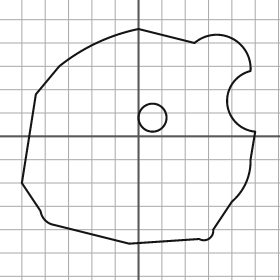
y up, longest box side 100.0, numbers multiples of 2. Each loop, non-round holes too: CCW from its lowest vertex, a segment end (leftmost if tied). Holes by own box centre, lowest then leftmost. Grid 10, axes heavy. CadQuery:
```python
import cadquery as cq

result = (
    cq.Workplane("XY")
    .moveTo(-4.0, -46.0)
    .lineTo(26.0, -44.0)
    .threePointArc((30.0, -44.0), (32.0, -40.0))
    .lineTo(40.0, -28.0)
    .threePointArc((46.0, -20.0), (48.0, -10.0))
    .lineTo(50.0, 2.0)
    .threePointArc((38.0, 14.0), (48.0, 28.0))
    .threePointArc((40.0, 42.0), (24.0, 40.0))
    .lineTo(0.0, 46.0)
    .threePointArc((-18.0, 40.0), (-34.0, 30.0))
    .lineTo(-44.0, 18.0)
    .lineTo(-50.0, -20.0)
    .lineTo(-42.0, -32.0)
    .threePointArc((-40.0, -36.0), (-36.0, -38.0))
    .close()
    .moveTo(6.0, 8.0)
    .circle(6.0)
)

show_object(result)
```